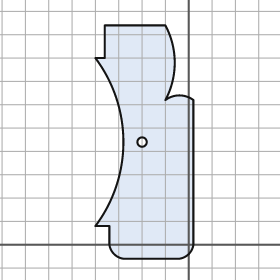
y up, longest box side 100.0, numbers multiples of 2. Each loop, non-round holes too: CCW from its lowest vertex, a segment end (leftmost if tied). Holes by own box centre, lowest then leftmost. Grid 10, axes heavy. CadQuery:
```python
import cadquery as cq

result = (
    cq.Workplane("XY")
    .moveTo(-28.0, -6.0)
    .lineTo(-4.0, -6.0)
    .threePointArc((0.0, -4.0), (2.0, 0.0))
    .lineTo(2.0, 62.0)
    .threePointArc((-4.0, 64.0), (-10.0, 62.0))
    .threePointArc((-6.0, 78.0), (-10.0, 94.0))
    .lineTo(-36.0, 94.0)
    .lineTo(-36.0, 80.0)
    .lineTo(-40.0, 80.0)
    .threePointArc((-28.0, 44.0), (-40.0, 8.0))
    .lineTo(-34.0, 8.0)
    .lineTo(-34.0, 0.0)
    .threePointArc((-32.0, -4.0), (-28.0, -6.0))
    .close()
    .moveTo(-20.0, 44.0)
    .circle(2.0)
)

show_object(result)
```